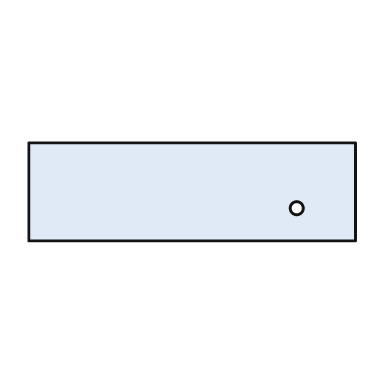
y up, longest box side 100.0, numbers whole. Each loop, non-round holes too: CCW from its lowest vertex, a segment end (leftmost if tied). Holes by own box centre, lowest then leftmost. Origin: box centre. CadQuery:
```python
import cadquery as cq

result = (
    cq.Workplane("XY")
    .moveTo(-50.0, -15.0)
    .lineTo(50.0, -15.0)
    .lineTo(50.0, 15.0)
    .lineTo(-50.0, 15.0)
    .close()
    .moveTo(32.0, -5.0)
    .circle(2.0)
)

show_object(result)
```